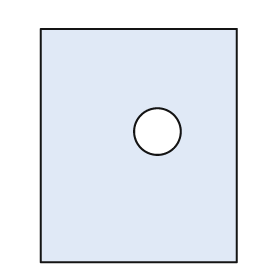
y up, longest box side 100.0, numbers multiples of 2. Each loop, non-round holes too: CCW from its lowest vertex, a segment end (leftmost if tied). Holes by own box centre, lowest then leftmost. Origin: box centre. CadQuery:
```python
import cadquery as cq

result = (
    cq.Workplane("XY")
    .moveTo(-42.0, -50.0)
    .lineTo(42.0, -50.0)
    .lineTo(42.0, 50.0)
    .lineTo(-42.0, 50.0)
    .close()
    .moveTo(8.0, 6.0)
    .circle(10.0)
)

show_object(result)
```